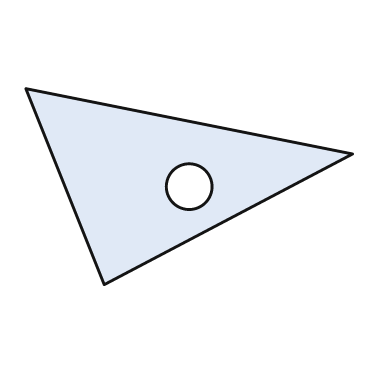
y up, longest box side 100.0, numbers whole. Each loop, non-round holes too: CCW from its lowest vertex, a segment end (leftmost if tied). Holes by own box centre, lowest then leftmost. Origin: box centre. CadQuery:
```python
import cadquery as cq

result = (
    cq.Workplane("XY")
    .moveTo(-26.0, -30.0)
    .lineTo(50.0, 10.0)
    .lineTo(-50.0, 30.0)
    .close()
    .moveTo(0.0, 0.0)
    .circle(7.0)
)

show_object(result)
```